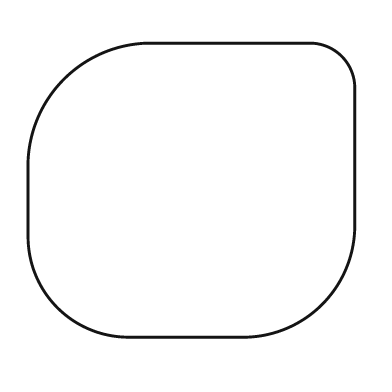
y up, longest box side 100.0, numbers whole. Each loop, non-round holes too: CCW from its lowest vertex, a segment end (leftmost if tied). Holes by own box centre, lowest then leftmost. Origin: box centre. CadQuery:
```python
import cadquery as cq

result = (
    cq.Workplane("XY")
    .moveTo(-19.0, -45.0)
    .lineTo(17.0, -45.0)
    .threePointArc((40.0, -35.0), (50.0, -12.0))
    .lineTo(50.0, 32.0)
    .threePointArc((46.0, 41.0), (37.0, 45.0))
    .lineTo(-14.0, 45.0)
    .threePointArc((-39.0, 34.0), (-50.0, 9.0))
    .lineTo(-50.0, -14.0)
    .threePointArc((-41.0, -36.0), (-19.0, -45.0))
    .close()
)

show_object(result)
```